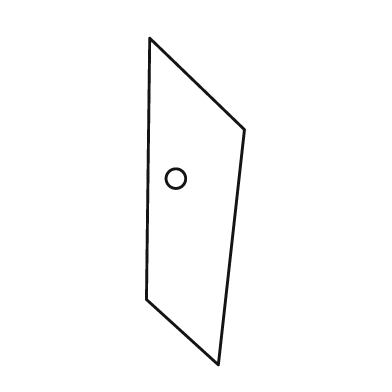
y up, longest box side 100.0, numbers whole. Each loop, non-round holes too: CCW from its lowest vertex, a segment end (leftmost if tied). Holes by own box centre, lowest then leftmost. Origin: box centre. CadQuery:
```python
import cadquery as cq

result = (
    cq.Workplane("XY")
    .moveTo(7.0, -50.0)
    .lineTo(15.0, 22.0)
    .lineTo(-14.0, 50.0)
    .lineTo(-15.0, -30.0)
    .close()
    .moveTo(-6.0, 7.0)
    .circle(3.0)
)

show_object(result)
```